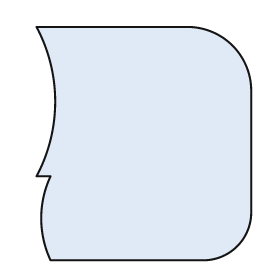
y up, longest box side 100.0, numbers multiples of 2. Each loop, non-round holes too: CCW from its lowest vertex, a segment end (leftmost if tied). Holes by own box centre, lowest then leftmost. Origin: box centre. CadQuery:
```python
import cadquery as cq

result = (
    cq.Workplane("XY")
    .moveTo(-40.0, -50.0)
    .lineTo(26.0, -50.0)
    .threePointArc((40.0, -44.0), (46.0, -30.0))
    .lineTo(46.0, 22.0)
    .threePointArc((38.0, 42.0), (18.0, 50.0))
    .lineTo(-46.0, 50.0)
    .threePointArc((-38.0, 18.0), (-46.0, -14.0))
    .lineTo(-40.0, -14.0)
    .threePointArc((-44.0, -32.0), (-40.0, -50.0))
    .close()
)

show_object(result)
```